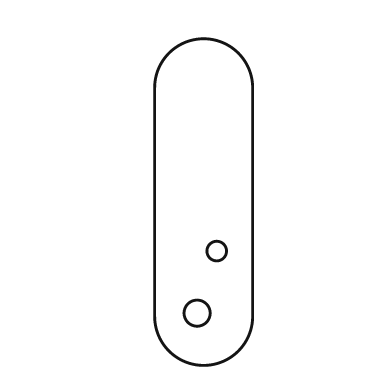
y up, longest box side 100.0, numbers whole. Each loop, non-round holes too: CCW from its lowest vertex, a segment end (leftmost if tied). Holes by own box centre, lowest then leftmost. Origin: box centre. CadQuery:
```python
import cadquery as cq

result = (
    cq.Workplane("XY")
    .moveTo(-15.0, -35.0)
    .threePointArc((0.0, -50.0), (15.0, -35.0))
    .lineTo(15.0, 35.0)
    .threePointArc((0.0, 50.0), (-15.0, 35.0))
    .close()
    .moveTo(-2.0, -34.0)
    .circle(4.0)
    .moveTo(4.0, -15.0)
    .circle(3.0)
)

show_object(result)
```